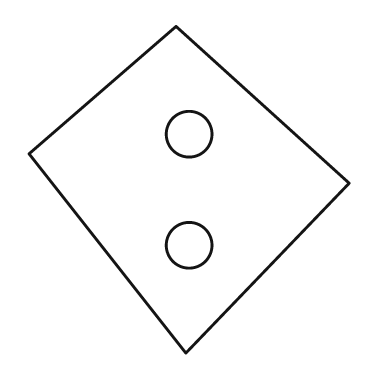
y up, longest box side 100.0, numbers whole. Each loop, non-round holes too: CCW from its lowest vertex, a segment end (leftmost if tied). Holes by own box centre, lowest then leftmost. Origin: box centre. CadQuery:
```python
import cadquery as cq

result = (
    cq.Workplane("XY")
    .moveTo(-1.0, -50.0)
    .lineTo(49.0, 2.0)
    .lineTo(-4.0, 50.0)
    .lineTo(-49.0, 11.0)
    .close()
    .moveTo(0.0, -17.0)
    .circle(7.0)
    .moveTo(0.0, 17.0)
    .circle(7.0)
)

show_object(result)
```